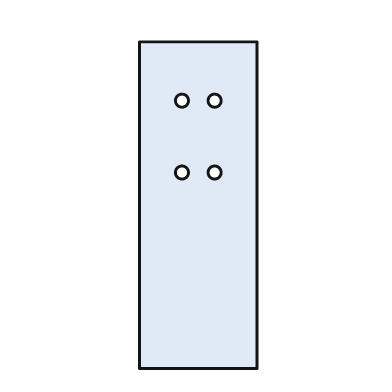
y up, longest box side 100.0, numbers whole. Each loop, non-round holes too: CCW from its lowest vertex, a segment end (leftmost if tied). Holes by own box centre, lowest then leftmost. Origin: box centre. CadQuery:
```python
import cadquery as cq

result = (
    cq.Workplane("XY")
    .moveTo(-18.0, -50.0)
    .lineTo(18.0, -50.0)
    .lineTo(18.0, 50.0)
    .lineTo(-18.0, 50.0)
    .close()
    .moveTo(-5.0, 10.0)
    .circle(2.0)
    .moveTo(5.0, 10.0)
    .circle(2.0)
    .moveTo(-5.0, 32.0)
    .circle(2.0)
    .moveTo(5.0, 32.0)
    .circle(2.0)
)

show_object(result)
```